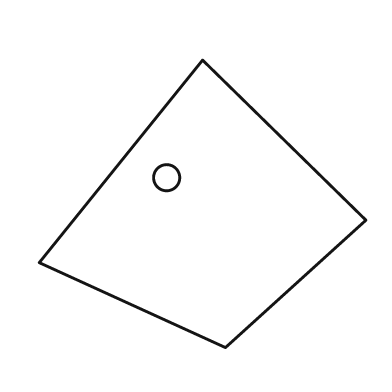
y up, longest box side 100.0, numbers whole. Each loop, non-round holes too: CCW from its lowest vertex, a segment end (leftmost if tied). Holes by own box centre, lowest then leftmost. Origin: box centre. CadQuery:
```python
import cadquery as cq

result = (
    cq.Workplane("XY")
    .moveTo(7.0, -44.0)
    .lineTo(50.0, -5.0)
    .lineTo(0.0, 44.0)
    .lineTo(-50.0, -18.0)
    .close()
    .moveTo(-11.0, 8.0)
    .circle(4.0)
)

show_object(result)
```